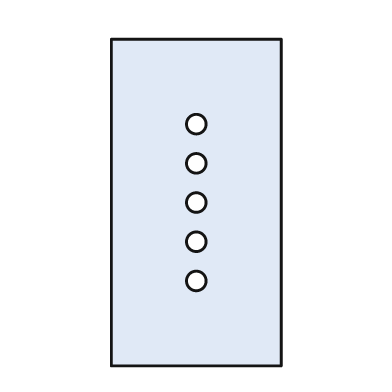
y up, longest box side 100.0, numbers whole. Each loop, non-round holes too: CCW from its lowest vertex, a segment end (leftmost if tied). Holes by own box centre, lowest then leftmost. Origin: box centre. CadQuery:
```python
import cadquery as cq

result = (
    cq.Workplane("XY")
    .moveTo(-26.0, -50.0)
    .lineTo(26.0, -50.0)
    .lineTo(26.0, 50.0)
    .lineTo(-26.0, 50.0)
    .close()
    .moveTo(0.0, -24.0)
    .circle(3.0)
    .moveTo(0.0, -12.0)
    .circle(3.0)
    .moveTo(0.0, 0.0)
    .circle(3.0)
    .moveTo(0.0, 12.0)
    .circle(3.0)
    .moveTo(0.0, 24.0)
    .circle(3.0)
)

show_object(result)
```